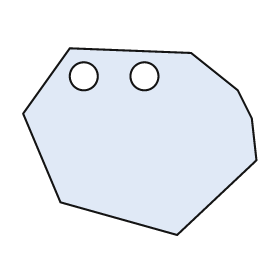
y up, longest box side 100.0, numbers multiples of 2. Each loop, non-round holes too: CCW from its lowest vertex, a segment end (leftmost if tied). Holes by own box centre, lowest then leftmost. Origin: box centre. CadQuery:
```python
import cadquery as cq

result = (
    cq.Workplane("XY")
    .moveTo(16.0, -40.0)
    .lineTo(50.0, -8.0)
    .lineTo(48.0, 10.0)
    .lineTo(42.0, 22.0)
    .lineTo(22.0, 38.0)
    .lineTo(-30.0, 40.0)
    .lineTo(-50.0, 12.0)
    .lineTo(-34.0, -26.0)
    .close()
    .moveTo(-24.0, 28.0)
    .circle(6.0)
    .moveTo(2.0, 28.0)
    .circle(6.0)
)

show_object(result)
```